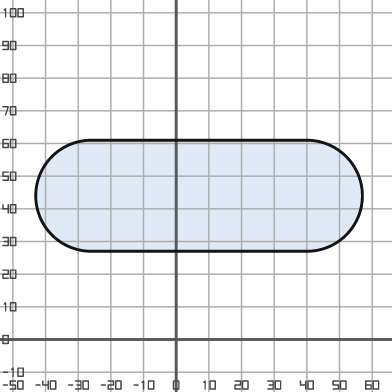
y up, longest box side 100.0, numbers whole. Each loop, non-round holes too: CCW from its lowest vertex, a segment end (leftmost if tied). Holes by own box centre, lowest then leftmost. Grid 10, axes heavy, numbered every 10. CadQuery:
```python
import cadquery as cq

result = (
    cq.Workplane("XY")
    .moveTo(-26.0, 27.0)
    .lineTo(40.0, 27.0)
    .threePointArc((57.0, 44.0), (40.0, 61.0))
    .lineTo(-26.0, 61.0)
    .threePointArc((-43.0, 44.0), (-26.0, 27.0))
    .close()
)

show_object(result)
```